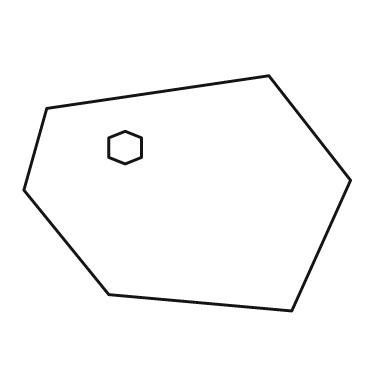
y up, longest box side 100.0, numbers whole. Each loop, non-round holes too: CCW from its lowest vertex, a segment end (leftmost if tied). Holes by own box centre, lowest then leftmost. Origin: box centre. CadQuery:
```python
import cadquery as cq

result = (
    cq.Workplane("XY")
    .moveTo(32.0, -36.0)
    .lineTo(50.0, 4.0)
    .lineTo(25.0, 36.0)
    .lineTo(-43.0, 26.0)
    .lineTo(-50.0, 1.0)
    .lineTo(-24.0, -31.0)
    .close()
    .moveTo(-19.0, 9.0)
    .lineTo(-14.0, 11.0)
    .lineTo(-14.0, 17.0)
    .lineTo(-19.0, 19.0)
    .lineTo(-24.0, 17.0)
    .lineTo(-24.0, 11.0)
    .close()
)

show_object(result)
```